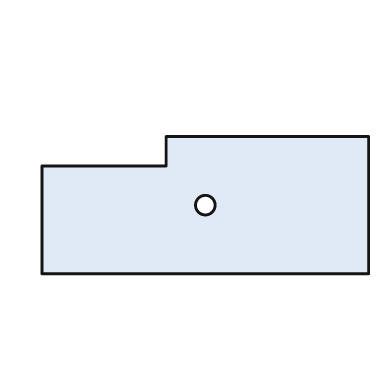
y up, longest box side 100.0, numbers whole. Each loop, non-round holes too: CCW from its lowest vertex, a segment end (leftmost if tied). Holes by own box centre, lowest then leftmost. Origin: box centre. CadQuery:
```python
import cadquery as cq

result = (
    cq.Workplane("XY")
    .moveTo(-50.0, -21.0)
    .lineTo(50.0, -21.0)
    .lineTo(50.0, 21.0)
    .lineTo(-12.0, 21.0)
    .lineTo(-12.0, 12.0)
    .lineTo(-50.0, 12.0)
    .close()
    .moveTo(0.0, 0.0)
    .circle(3.0)
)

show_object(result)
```